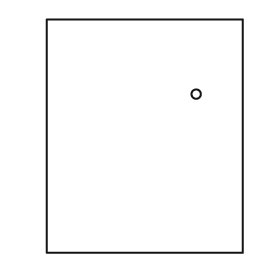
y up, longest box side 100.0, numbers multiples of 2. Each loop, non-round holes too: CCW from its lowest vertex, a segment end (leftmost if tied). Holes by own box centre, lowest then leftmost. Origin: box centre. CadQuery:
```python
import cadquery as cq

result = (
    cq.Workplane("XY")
    .moveTo(-42.0, -50.0)
    .lineTo(42.0, -50.0)
    .lineTo(42.0, 50.0)
    .lineTo(-42.0, 50.0)
    .close()
    .moveTo(22.0, 18.0)
    .circle(2.0)
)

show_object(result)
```